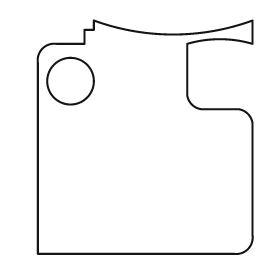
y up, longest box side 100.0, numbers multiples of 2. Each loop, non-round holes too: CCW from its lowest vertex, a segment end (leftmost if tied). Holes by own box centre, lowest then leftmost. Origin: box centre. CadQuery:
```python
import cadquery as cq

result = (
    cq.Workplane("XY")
    .moveTo(-46.0, -50.0)
    .lineTo(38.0, -50.0)
    .threePointArc((44.0, -48.0), (46.0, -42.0))
    .lineTo(46.0, 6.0)
    .threePointArc((44.0, 10.0), (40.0, 12.0))
    .lineTo(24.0, 12.0)
    .threePointArc((20.0, 14.0), (18.0, 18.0))
    .lineTo(18.0, 40.0)
    .threePointArc((32.0, 42.0), (46.0, 40.0))
    .lineTo(46.0, 50.0)
    .threePointArc((12.0, 44.0), (-22.0, 50.0))
    .lineTo(-22.0, 46.0)
    .lineTo(-26.0, 46.0)
    .lineTo(-26.0, 40.0)
    .lineTo(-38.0, 40.0)
    .threePointArc((-44.0, 38.0), (-46.0, 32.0))
    .close()
    .moveTo(-32.0, 24.0)
    .circle(10.0)
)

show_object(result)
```